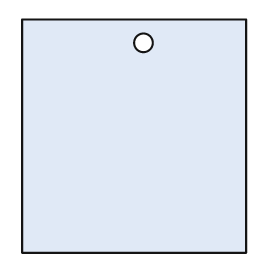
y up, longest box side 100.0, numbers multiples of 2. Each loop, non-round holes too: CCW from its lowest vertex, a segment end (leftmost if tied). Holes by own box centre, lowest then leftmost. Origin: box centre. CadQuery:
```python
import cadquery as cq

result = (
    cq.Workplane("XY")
    .moveTo(-48.0, -50.0)
    .lineTo(48.0, -50.0)
    .lineTo(48.0, 50.0)
    .lineTo(-48.0, 50.0)
    .close()
    .moveTo(4.0, 40.0)
    .circle(4.0)
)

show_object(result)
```